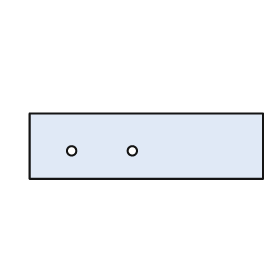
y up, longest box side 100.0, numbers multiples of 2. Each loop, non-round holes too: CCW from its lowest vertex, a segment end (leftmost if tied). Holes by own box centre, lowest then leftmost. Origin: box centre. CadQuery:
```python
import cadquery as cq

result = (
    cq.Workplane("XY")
    .moveTo(-50.0, -14.0)
    .lineTo(50.0, -14.0)
    .lineTo(50.0, 14.0)
    .lineTo(-50.0, 14.0)
    .close()
    .moveTo(-32.0, -2.0)
    .circle(2.0)
    .moveTo(-6.0, -2.0)
    .circle(2.0)
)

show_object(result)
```